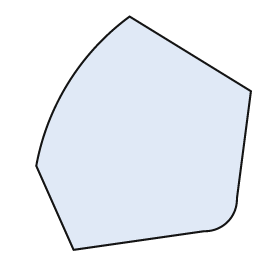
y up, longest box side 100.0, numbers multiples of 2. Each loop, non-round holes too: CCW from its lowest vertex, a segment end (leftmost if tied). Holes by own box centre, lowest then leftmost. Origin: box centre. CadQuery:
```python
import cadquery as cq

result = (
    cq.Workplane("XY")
    .moveTo(-30.0, -50.0)
    .lineTo(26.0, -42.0)
    .threePointArc((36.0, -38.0), (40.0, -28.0))
    .lineTo(46.0, 18.0)
    .lineTo(-6.0, 50.0)
    .threePointArc((-32.0, 22.0), (-46.0, -14.0))
    .close()
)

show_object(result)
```